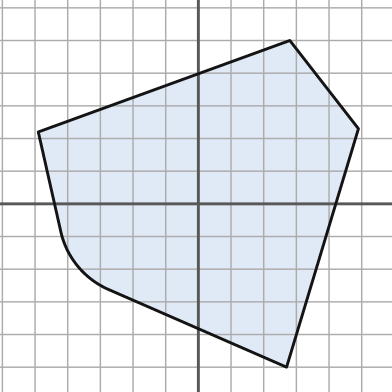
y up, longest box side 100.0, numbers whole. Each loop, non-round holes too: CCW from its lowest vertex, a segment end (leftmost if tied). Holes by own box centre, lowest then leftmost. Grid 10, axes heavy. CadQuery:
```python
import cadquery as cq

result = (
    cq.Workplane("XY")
    .moveTo(27.0, -50.0)
    .lineTo(49.0, 23.0)
    .lineTo(28.0, 50.0)
    .lineTo(-49.0, 22.0)
    .lineTo(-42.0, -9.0)
    .threePointArc((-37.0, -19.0), (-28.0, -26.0))
    .close()
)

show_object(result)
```